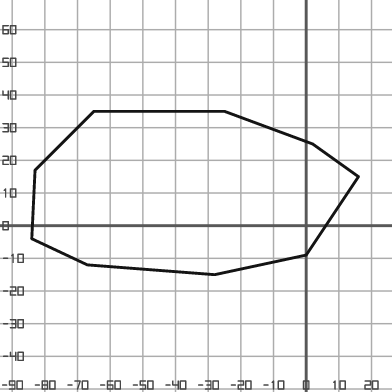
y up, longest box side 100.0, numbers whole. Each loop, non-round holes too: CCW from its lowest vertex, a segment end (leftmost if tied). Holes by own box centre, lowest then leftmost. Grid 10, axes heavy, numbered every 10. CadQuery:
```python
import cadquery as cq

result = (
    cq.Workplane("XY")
    .moveTo(-28.0, -15.0)
    .lineTo(0.0, -9.0)
    .lineTo(16.0, 15.0)
    .lineTo(2.0, 25.0)
    .lineTo(-25.0, 35.0)
    .lineTo(-65.0, 35.0)
    .lineTo(-83.0, 17.0)
    .lineTo(-84.0, -4.0)
    .lineTo(-67.0, -12.0)
    .close()
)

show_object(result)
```